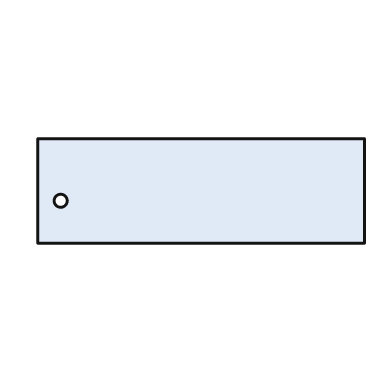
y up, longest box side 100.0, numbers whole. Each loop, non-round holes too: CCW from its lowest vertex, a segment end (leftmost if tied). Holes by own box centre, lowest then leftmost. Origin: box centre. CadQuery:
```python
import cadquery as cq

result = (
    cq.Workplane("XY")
    .moveTo(-50.0, -16.0)
    .lineTo(50.0, -16.0)
    .lineTo(50.0, 16.0)
    .lineTo(-50.0, 16.0)
    .close()
    .moveTo(-43.0, -3.0)
    .circle(2.0)
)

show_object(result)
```